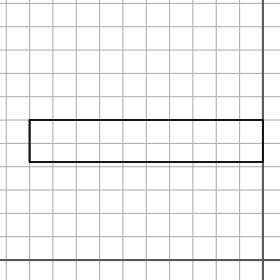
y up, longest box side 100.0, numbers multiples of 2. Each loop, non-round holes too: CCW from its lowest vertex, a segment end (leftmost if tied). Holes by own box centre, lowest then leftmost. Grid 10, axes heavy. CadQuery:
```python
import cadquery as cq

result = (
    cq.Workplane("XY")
    .moveTo(-100.0, 42.0)
    .lineTo(0.0, 42.0)
    .lineTo(0.0, 60.0)
    .lineTo(-100.0, 60.0)
    .close()
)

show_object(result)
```